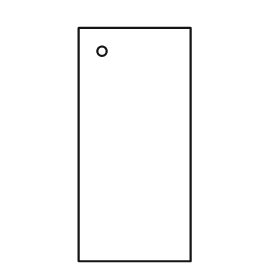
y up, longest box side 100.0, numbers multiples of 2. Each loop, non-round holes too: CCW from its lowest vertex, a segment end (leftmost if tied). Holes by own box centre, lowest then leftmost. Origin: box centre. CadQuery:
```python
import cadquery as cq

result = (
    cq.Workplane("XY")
    .moveTo(-24.0, -50.0)
    .lineTo(24.0, -50.0)
    .lineTo(24.0, 50.0)
    .lineTo(-24.0, 50.0)
    .close()
    .moveTo(-14.0, 40.0)
    .circle(2.0)
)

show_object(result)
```